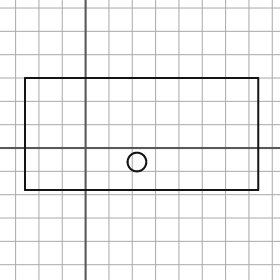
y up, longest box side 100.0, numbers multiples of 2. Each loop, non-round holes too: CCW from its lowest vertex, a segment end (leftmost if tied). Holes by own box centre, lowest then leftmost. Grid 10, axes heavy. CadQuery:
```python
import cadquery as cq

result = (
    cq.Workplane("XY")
    .moveTo(-26.0, -18.0)
    .lineTo(74.0, -18.0)
    .lineTo(74.0, 30.0)
    .lineTo(-26.0, 30.0)
    .close()
    .moveTo(22.0, -6.0)
    .circle(4.0)
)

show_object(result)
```